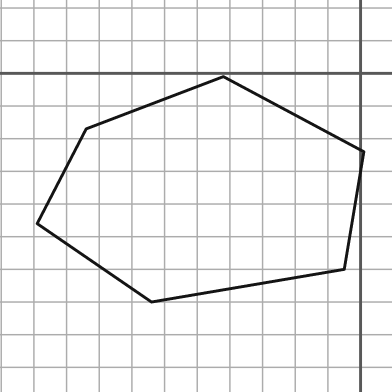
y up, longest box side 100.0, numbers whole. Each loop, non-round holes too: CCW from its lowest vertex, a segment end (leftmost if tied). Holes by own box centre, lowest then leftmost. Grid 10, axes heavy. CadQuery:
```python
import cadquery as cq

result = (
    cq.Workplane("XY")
    .moveTo(-64.0, -70.0)
    .lineTo(-5.0, -60.0)
    .lineTo(1.0, -24.0)
    .lineTo(-42.0, -1.0)
    .lineTo(-84.0, -17.0)
    .lineTo(-99.0, -46.0)
    .close()
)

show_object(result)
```